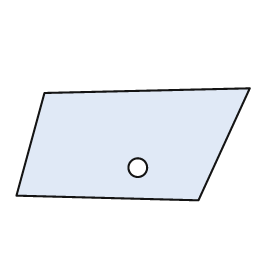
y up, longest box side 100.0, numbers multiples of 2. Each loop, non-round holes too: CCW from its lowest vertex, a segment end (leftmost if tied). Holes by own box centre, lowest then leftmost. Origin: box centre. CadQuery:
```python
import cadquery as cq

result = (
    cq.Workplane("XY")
    .moveTo(28.0, -24.0)
    .lineTo(50.0, 24.0)
    .lineTo(-38.0, 22.0)
    .lineTo(-50.0, -22.0)
    .close()
    .moveTo(2.0, -10.0)
    .circle(4.0)
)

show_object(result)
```